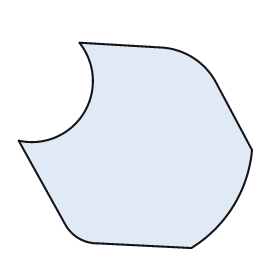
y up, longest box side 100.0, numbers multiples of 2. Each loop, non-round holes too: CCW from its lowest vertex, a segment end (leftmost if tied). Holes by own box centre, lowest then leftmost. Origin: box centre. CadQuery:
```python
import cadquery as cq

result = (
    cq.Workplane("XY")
    .moveTo(24.0, -44.0)
    .threePointArc((42.0, -26.0), (50.0, -2.0))
    .lineTo(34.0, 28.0)
    .threePointArc((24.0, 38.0), (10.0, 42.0))
    .lineTo(-24.0, 44.0)
    .threePointArc((-22.0, 14.0), (-50.0, 2.0))
    .lineTo(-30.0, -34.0)
    .threePointArc((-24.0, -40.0), (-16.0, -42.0))
    .close()
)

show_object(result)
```